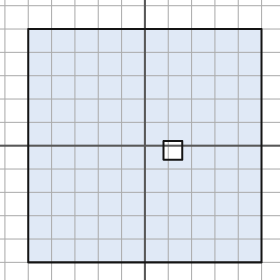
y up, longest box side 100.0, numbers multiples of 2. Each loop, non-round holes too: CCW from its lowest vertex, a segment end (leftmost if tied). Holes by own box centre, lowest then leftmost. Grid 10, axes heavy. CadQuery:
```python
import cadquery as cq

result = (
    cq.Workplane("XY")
    .moveTo(-50.0, -50.0)
    .lineTo(50.0, -50.0)
    .lineTo(50.0, 50.0)
    .lineTo(-50.0, 50.0)
    .close()
    .moveTo(8.0, -6.0)
    .lineTo(16.0, -6.0)
    .lineTo(16.0, 2.0)
    .lineTo(8.0, 2.0)
    .close()
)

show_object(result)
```